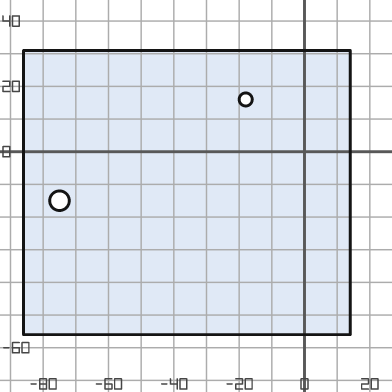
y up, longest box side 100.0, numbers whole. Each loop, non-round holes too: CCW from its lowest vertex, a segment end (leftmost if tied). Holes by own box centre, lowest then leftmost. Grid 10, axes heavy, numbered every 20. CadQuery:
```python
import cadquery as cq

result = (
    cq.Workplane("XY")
    .moveTo(-86.0, -56.0)
    .lineTo(14.0, -56.0)
    .lineTo(14.0, 31.0)
    .lineTo(-86.0, 31.0)
    .close()
    .moveTo(-75.0, -15.0)
    .circle(3.0)
    .moveTo(-18.0, 16.0)
    .circle(2.0)
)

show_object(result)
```